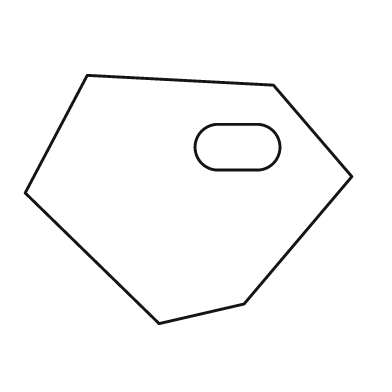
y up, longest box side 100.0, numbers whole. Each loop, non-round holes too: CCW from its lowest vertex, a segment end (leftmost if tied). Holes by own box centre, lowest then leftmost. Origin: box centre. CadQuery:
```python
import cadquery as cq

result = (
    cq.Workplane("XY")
    .moveTo(-9.0, -38.0)
    .lineTo(17.0, -32.0)
    .lineTo(50.0, 7.0)
    .lineTo(26.0, 35.0)
    .lineTo(-31.0, 38.0)
    .lineTo(-50.0, 2.0)
    .close()
    .moveTo(9.0, 9.0)
    .lineTo(21.0, 9.0)
    .threePointArc((28.0, 16.0), (21.0, 23.0))
    .lineTo(9.0, 23.0)
    .threePointArc((2.0, 16.0), (9.0, 9.0))
    .close()
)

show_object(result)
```